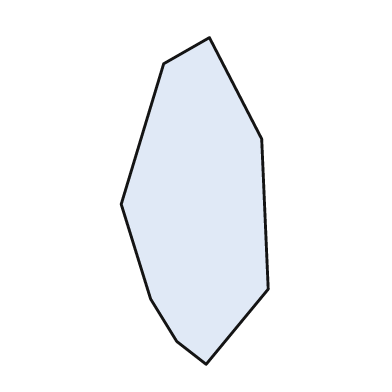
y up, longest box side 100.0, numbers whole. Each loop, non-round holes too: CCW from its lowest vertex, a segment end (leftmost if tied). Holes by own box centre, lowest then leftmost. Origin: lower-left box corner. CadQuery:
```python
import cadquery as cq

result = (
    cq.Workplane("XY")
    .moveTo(26.0, 0.0)
    .lineTo(45.0, 23.0)
    .lineTo(43.0, 69.0)
    .lineTo(27.0, 100.0)
    .lineTo(13.0, 92.0)
    .lineTo(0.0, 49.0)
    .lineTo(9.0, 20.0)
    .lineTo(17.0, 7.0)
    .close()
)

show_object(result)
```